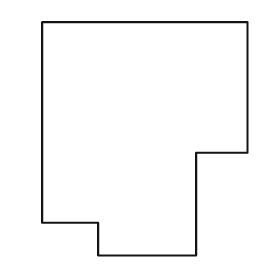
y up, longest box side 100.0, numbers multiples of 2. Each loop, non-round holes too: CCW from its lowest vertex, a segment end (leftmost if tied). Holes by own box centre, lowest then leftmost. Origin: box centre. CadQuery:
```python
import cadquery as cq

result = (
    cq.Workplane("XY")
    .moveTo(-20.0, -50.0)
    .lineTo(22.0, -50.0)
    .lineTo(22.0, -6.0)
    .lineTo(44.0, -6.0)
    .lineTo(44.0, 50.0)
    .lineTo(-44.0, 50.0)
    .lineTo(-44.0, -36.0)
    .lineTo(-20.0, -36.0)
    .close()
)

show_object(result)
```